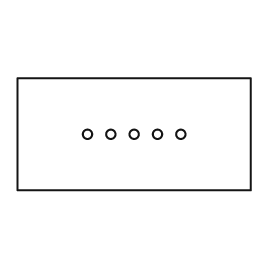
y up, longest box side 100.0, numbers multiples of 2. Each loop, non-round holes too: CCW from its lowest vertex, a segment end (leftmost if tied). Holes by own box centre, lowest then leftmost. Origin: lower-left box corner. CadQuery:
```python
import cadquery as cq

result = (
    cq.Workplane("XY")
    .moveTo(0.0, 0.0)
    .lineTo(100.0, 0.0)
    .lineTo(100.0, 48.0)
    .lineTo(0.0, 48.0)
    .close()
    .moveTo(30.0, 24.0)
    .circle(2.0)
    .moveTo(40.0, 24.0)
    .circle(2.0)
    .moveTo(50.0, 24.0)
    .circle(2.0)
    .moveTo(60.0, 24.0)
    .circle(2.0)
    .moveTo(70.0, 24.0)
    .circle(2.0)
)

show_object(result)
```